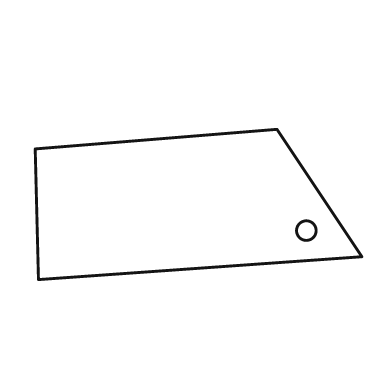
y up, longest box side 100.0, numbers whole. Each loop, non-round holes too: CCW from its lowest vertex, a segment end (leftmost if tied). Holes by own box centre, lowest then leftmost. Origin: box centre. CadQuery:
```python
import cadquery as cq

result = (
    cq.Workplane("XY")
    .moveTo(-49.0, -23.0)
    .lineTo(50.0, -16.0)
    .lineTo(24.0, 23.0)
    .lineTo(-50.0, 17.0)
    .close()
    .moveTo(33.0, -8.0)
    .circle(3.0)
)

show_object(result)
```